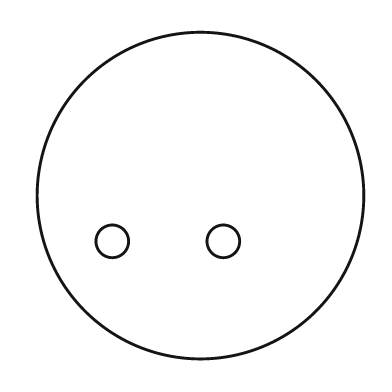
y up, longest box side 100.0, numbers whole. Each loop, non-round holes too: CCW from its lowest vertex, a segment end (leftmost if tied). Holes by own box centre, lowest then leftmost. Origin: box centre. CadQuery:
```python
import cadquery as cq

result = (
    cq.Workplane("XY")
    .moveTo(0.0, 0.0)
    .circle(50.0)
    .moveTo(-27.0, -14.0)
    .circle(5.0)
    .moveTo(7.0, -14.0)
    .circle(5.0)
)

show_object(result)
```